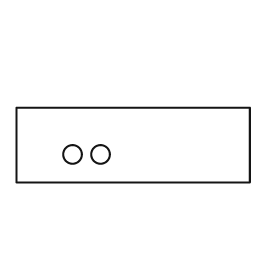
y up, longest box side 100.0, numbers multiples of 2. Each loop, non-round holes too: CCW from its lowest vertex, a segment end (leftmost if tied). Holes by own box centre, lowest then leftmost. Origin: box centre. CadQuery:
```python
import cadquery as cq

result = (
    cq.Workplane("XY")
    .moveTo(-50.0, -16.0)
    .lineTo(50.0, -16.0)
    .lineTo(50.0, 16.0)
    .lineTo(-50.0, 16.0)
    .close()
    .moveTo(-26.0, -4.0)
    .circle(4.0)
    .moveTo(-14.0, -4.0)
    .circle(4.0)
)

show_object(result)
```